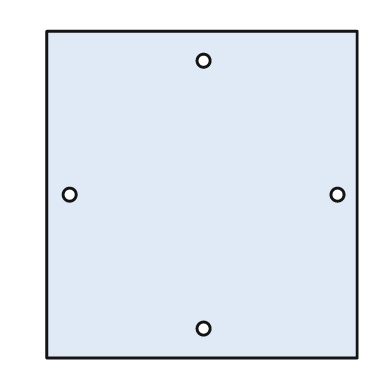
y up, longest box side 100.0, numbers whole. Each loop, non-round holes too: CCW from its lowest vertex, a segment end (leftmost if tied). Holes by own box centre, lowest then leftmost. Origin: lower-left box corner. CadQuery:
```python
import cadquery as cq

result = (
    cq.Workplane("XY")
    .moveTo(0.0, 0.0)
    .lineTo(95.0, 0.0)
    .lineTo(95.0, 100.0)
    .lineTo(0.0, 100.0)
    .close()
    .moveTo(48.0, 9.0)
    .circle(2.0)
    .moveTo(7.0, 50.0)
    .circle(2.0)
    .moveTo(89.0, 50.0)
    .circle(2.0)
    .moveTo(48.0, 91.0)
    .circle(2.0)
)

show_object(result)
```